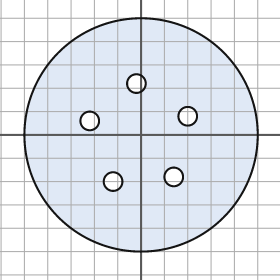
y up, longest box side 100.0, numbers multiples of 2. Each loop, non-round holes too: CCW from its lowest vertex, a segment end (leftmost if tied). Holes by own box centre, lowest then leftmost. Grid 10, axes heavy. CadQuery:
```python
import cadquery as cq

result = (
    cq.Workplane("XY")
    .moveTo(0.0, 0.0)
    .circle(50.0)
    .moveTo(-12.0, -20.0)
    .circle(4.0)
    .moveTo(14.0, -18.0)
    .circle(4.0)
    .moveTo(-22.0, 6.0)
    .circle(4.0)
    .moveTo(20.0, 8.0)
    .circle(4.0)
    .moveTo(-2.0, 22.0)
    .circle(4.0)
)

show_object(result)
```